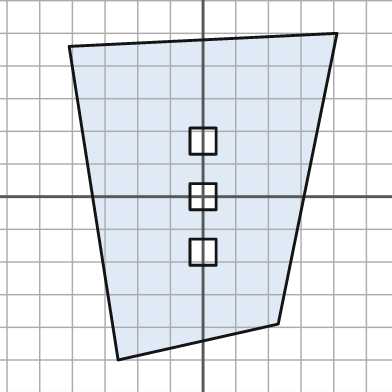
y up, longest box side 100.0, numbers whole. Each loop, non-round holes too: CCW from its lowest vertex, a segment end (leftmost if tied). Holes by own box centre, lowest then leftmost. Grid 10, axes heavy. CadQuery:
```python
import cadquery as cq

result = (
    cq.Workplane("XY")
    .moveTo(-26.0, -50.0)
    .lineTo(23.0, -39.0)
    .lineTo(41.0, 50.0)
    .lineTo(-41.0, 46.0)
    .close()
    .moveTo(-4.0, -21.0)
    .lineTo(4.0, -21.0)
    .lineTo(4.0, -13.0)
    .lineTo(-4.0, -13.0)
    .close()
    .moveTo(-4.0, -4.0)
    .lineTo(4.0, -4.0)
    .lineTo(4.0, 4.0)
    .lineTo(-4.0, 4.0)
    .close()
    .moveTo(-4.0, 13.0)
    .lineTo(4.0, 13.0)
    .lineTo(4.0, 21.0)
    .lineTo(-4.0, 21.0)
    .close()
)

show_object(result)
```